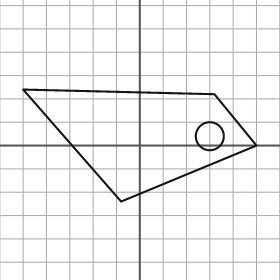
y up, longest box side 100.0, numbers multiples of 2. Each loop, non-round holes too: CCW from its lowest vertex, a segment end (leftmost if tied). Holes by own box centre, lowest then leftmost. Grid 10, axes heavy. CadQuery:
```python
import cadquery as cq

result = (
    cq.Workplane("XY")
    .moveTo(-8.0, -24.0)
    .lineTo(50.0, 0.0)
    .lineTo(32.0, 22.0)
    .lineTo(-50.0, 24.0)
    .close()
    .moveTo(30.0, 4.0)
    .circle(6.0)
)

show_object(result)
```